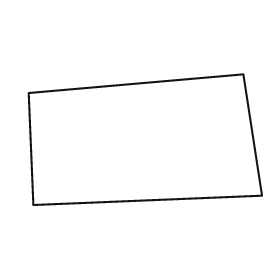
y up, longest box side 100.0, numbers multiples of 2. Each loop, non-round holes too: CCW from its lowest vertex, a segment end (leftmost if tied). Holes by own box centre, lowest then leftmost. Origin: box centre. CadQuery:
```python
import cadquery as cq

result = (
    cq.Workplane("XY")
    .moveTo(-48.0, -28.0)
    .lineTo(50.0, -24.0)
    .lineTo(42.0, 28.0)
    .lineTo(-50.0, 20.0)
    .close()
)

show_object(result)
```